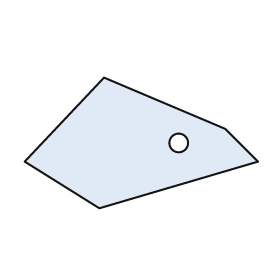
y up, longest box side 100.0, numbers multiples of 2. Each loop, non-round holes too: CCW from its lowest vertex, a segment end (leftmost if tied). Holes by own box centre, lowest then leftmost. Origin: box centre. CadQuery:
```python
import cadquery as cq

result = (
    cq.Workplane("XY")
    .moveTo(-18.0, -28.0)
    .lineTo(50.0, -8.0)
    .lineTo(36.0, 6.0)
    .lineTo(-16.0, 28.0)
    .lineTo(-50.0, -8.0)
    .close()
    .moveTo(16.0, 0.0)
    .circle(4.0)
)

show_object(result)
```